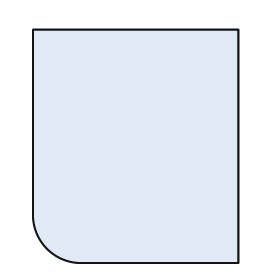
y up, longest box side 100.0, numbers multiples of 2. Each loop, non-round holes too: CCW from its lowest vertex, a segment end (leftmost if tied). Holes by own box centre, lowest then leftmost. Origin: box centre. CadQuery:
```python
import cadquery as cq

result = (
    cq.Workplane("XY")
    .moveTo(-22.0, -50.0)
    .lineTo(44.0, -50.0)
    .lineTo(44.0, 50.0)
    .lineTo(-44.0, 50.0)
    .lineTo(-44.0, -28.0)
    .threePointArc((-38.0, -44.0), (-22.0, -50.0))
    .close()
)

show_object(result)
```